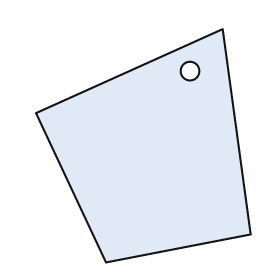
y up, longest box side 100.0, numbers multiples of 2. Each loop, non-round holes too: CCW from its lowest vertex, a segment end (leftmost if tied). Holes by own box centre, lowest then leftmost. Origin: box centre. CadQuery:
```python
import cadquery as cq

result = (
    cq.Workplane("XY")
    .moveTo(-16.0, -50.0)
    .lineTo(46.0, -38.0)
    .lineTo(34.0, 50.0)
    .lineTo(-46.0, 14.0)
    .close()
    .moveTo(20.0, 32.0)
    .circle(4.0)
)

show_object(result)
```